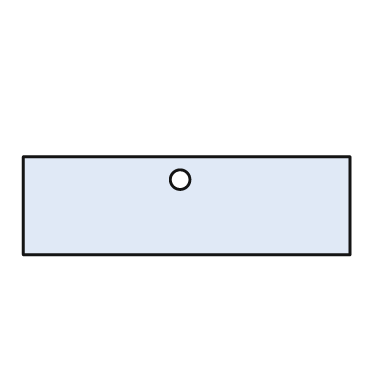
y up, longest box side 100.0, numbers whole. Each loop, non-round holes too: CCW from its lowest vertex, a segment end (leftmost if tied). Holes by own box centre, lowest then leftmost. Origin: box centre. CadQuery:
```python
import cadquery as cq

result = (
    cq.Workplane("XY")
    .moveTo(-50.0, -15.0)
    .lineTo(50.0, -15.0)
    .lineTo(50.0, 15.0)
    .lineTo(-50.0, 15.0)
    .close()
    .moveTo(-2.0, 8.0)
    .circle(3.0)
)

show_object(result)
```